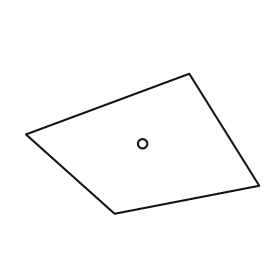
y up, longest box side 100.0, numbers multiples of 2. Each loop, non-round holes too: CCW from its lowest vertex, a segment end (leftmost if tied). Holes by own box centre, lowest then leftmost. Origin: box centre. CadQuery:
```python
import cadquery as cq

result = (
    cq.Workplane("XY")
    .moveTo(-12.0, -30.0)
    .lineTo(50.0, -18.0)
    .lineTo(20.0, 30.0)
    .lineTo(-50.0, 4.0)
    .close()
    .moveTo(0.0, 0.0)
    .circle(2.0)
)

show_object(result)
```